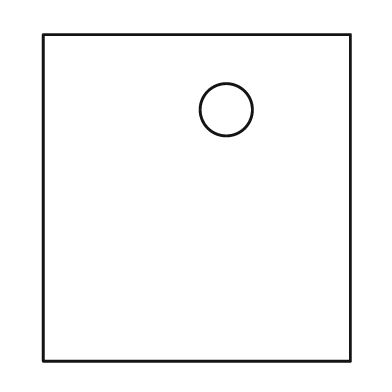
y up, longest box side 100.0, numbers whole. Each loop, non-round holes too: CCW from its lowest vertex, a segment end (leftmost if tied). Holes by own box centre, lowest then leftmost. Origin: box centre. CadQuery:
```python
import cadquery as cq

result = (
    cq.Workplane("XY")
    .moveTo(-47.0, -50.0)
    .lineTo(47.0, -50.0)
    .lineTo(47.0, 50.0)
    .lineTo(-47.0, 50.0)
    .close()
    .moveTo(9.0, 27.0)
    .circle(8.0)
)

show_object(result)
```